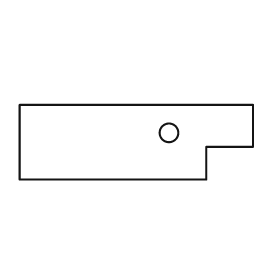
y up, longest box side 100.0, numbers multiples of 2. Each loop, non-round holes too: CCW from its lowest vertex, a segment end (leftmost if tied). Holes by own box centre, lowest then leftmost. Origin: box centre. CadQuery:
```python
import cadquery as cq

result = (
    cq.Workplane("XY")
    .moveTo(-50.0, -16.0)
    .lineTo(30.0, -16.0)
    .lineTo(30.0, -2.0)
    .lineTo(50.0, -2.0)
    .lineTo(50.0, 16.0)
    .lineTo(-50.0, 16.0)
    .close()
    .moveTo(14.0, 4.0)
    .circle(4.0)
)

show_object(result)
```